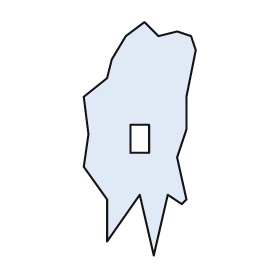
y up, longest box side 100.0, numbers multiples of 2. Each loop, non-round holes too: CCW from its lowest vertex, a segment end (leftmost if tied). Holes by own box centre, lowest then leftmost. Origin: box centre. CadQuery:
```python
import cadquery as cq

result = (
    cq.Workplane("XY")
    .moveTo(6.0, -50.0)
    .lineTo(12.0, -24.0)
    .lineTo(18.0, -28.0)
    .lineTo(20.0, -26.0)
    .lineTo(16.0, -8.0)
    .lineTo(20.0, 4.0)
    .lineTo(20.0, 18.0)
    .lineTo(24.0, 38.0)
    .lineTo(22.0, 44.0)
    .lineTo(16.0, 46.0)
    .lineTo(8.0, 44.0)
    .lineTo(2.0, 50.0)
    .lineTo(-6.0, 44.0)
    .lineTo(-12.0, 34.0)
    .lineTo(-14.0, 26.0)
    .lineTo(-24.0, 18.0)
    .lineTo(-22.0, 2.0)
    .lineTo(-24.0, -12.0)
    .lineTo(-14.0, -26.0)
    .lineTo(-14.0, -44.0)
    .lineTo(0.0, -24.0)
    .close()
    .moveTo(-4.0, -6.0)
    .lineTo(4.0, -6.0)
    .lineTo(4.0, 6.0)
    .lineTo(-4.0, 6.0)
    .close()
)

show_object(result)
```